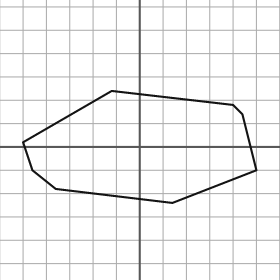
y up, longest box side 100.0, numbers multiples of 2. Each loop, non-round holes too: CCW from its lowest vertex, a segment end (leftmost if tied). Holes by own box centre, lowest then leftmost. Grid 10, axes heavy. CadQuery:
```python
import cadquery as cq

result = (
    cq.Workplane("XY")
    .moveTo(14.0, -24.0)
    .lineTo(50.0, -10.0)
    .lineTo(44.0, 14.0)
    .lineTo(40.0, 18.0)
    .lineTo(-12.0, 24.0)
    .lineTo(-50.0, 2.0)
    .lineTo(-46.0, -10.0)
    .lineTo(-36.0, -18.0)
    .close()
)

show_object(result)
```